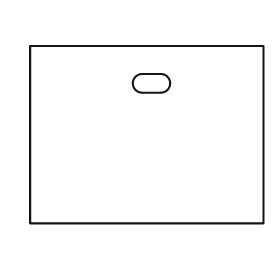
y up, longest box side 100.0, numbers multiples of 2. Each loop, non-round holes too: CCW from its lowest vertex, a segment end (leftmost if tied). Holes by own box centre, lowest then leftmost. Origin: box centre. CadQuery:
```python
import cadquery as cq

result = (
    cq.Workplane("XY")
    .moveTo(-50.0, -38.0)
    .lineTo(50.0, -38.0)
    .lineTo(50.0, 38.0)
    .lineTo(-50.0, 38.0)
    .close()
    .moveTo(-2.0, 18.0)
    .lineTo(6.0, 18.0)
    .threePointArc((10.0, 22.0), (6.0, 26.0))
    .lineTo(-2.0, 26.0)
    .threePointArc((-6.0, 22.0), (-2.0, 18.0))
    .close()
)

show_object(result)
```